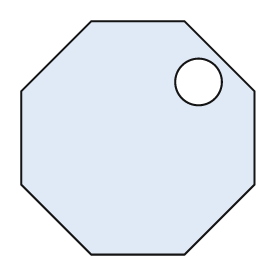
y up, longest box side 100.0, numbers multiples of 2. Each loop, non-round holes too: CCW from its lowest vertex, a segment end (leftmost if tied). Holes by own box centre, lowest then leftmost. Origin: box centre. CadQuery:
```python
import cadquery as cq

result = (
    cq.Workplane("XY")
    .moveTo(-20.0, -50.0)
    .lineTo(20.0, -50.0)
    .lineTo(50.0, -20.0)
    .lineTo(50.0, 20.0)
    .lineTo(20.0, 50.0)
    .lineTo(-20.0, 50.0)
    .lineTo(-50.0, 20.0)
    .lineTo(-50.0, -20.0)
    .close()
    .moveTo(26.0, 24.0)
    .circle(10.0)
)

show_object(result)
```